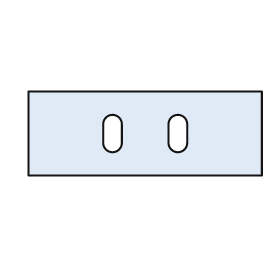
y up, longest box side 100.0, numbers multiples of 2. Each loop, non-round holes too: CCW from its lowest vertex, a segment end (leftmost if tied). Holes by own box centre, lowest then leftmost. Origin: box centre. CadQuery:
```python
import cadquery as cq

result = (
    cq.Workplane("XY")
    .moveTo(-50.0, -18.0)
    .lineTo(50.0, -18.0)
    .lineTo(50.0, 18.0)
    .lineTo(-50.0, 18.0)
    .close()
    .moveTo(-18.0, -4.0)
    .threePointArc((-14.0, -8.0), (-10.0, -4.0))
    .lineTo(-10.0, 4.0)
    .threePointArc((-14.0, 8.0), (-18.0, 4.0))
    .close()
    .moveTo(10.0, -4.0)
    .threePointArc((14.0, -8.0), (18.0, -4.0))
    .lineTo(18.0, 4.0)
    .threePointArc((14.0, 8.0), (10.0, 4.0))
    .close()
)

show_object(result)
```